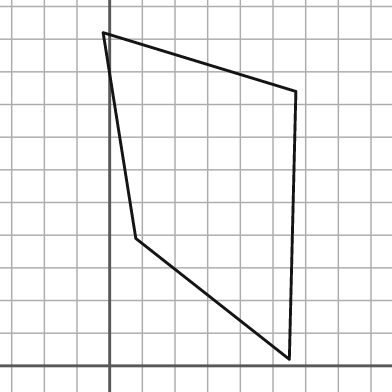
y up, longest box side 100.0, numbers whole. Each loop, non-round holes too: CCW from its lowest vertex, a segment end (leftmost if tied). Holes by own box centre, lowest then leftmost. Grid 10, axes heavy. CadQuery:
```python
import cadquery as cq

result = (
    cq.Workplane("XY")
    .moveTo(55.0, 2.0)
    .lineTo(57.0, 84.0)
    .lineTo(-2.0, 102.0)
    .lineTo(8.0, 39.0)
    .close()
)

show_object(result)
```